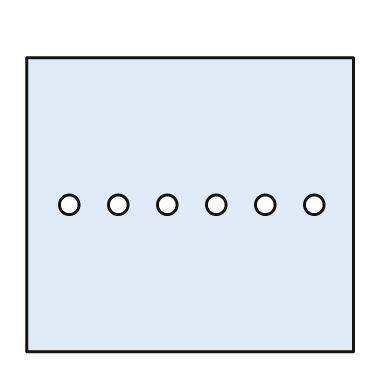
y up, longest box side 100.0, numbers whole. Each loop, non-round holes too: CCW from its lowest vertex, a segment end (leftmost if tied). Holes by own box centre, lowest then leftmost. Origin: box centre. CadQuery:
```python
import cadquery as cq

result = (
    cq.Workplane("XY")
    .moveTo(-50.0, -45.0)
    .lineTo(50.0, -45.0)
    .lineTo(50.0, 45.0)
    .lineTo(-50.0, 45.0)
    .close()
    .moveTo(-37.0, 0.0)
    .circle(3.0)
    .moveTo(-22.0, 0.0)
    .circle(3.0)
    .moveTo(-7.0, 0.0)
    .circle(3.0)
    .moveTo(8.0, 0.0)
    .circle(3.0)
    .moveTo(23.0, 0.0)
    .circle(3.0)
    .moveTo(38.0, 0.0)
    .circle(3.0)
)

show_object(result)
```